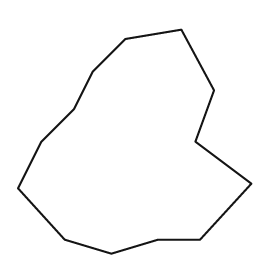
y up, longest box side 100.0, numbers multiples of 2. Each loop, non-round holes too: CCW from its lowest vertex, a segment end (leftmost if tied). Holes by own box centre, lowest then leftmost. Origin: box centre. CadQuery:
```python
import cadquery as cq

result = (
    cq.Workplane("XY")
    .moveTo(-10.0, -48.0)
    .lineTo(10.0, -42.0)
    .lineTo(28.0, -42.0)
    .lineTo(50.0, -18.0)
    .lineTo(26.0, 0.0)
    .lineTo(34.0, 22.0)
    .lineTo(20.0, 48.0)
    .lineTo(-4.0, 44.0)
    .lineTo(-18.0, 30.0)
    .lineTo(-26.0, 14.0)
    .lineTo(-40.0, 0.0)
    .lineTo(-50.0, -20.0)
    .lineTo(-30.0, -42.0)
    .close()
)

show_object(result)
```